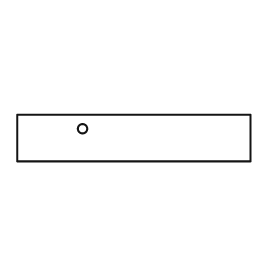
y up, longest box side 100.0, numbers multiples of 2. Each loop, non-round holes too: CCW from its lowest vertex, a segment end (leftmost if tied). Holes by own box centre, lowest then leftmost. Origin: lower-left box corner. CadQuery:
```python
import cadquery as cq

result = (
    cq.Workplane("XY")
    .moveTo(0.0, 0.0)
    .lineTo(100.0, 0.0)
    .lineTo(100.0, 20.0)
    .lineTo(0.0, 20.0)
    .close()
    .moveTo(28.0, 14.0)
    .circle(2.0)
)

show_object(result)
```